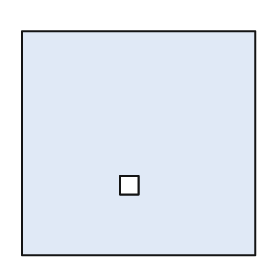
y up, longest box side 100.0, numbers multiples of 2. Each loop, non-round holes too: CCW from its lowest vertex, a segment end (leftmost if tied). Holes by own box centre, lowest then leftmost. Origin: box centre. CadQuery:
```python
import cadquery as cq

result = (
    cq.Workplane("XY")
    .moveTo(-50.0, -48.0)
    .lineTo(50.0, -48.0)
    .lineTo(50.0, 48.0)
    .lineTo(-50.0, 48.0)
    .close()
    .moveTo(-8.0, -22.0)
    .lineTo(0.0, -22.0)
    .lineTo(0.0, -14.0)
    .lineTo(-8.0, -14.0)
    .close()
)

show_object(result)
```